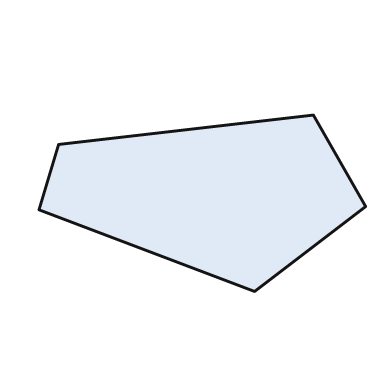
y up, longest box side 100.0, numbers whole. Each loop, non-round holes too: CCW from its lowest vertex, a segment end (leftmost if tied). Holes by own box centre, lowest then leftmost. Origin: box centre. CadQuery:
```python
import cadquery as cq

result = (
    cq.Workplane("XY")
    .moveTo(16.0, -27.0)
    .lineTo(50.0, -1.0)
    .lineTo(34.0, 27.0)
    .lineTo(-44.0, 18.0)
    .lineTo(-50.0, -2.0)
    .close()
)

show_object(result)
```